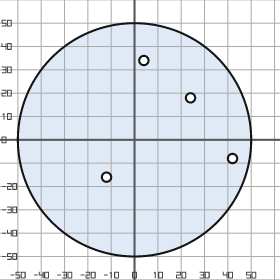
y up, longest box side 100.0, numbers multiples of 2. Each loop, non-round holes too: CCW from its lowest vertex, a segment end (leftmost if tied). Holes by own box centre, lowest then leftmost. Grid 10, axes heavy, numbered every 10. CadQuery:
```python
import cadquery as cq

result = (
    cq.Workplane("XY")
    .moveTo(0.0, 0.0)
    .circle(50.0)
    .moveTo(-12.0, -16.0)
    .circle(2.0)
    .moveTo(42.0, -8.0)
    .circle(2.0)
    .moveTo(24.0, 18.0)
    .circle(2.0)
    .moveTo(4.0, 34.0)
    .circle(2.0)
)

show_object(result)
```